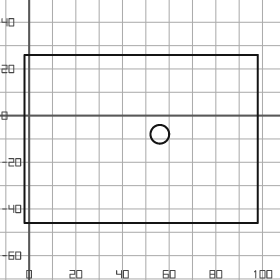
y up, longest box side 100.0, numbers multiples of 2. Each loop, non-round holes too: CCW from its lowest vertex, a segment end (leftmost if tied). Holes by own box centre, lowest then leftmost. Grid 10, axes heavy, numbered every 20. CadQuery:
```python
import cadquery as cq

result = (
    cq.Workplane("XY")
    .moveTo(-2.0, -46.0)
    .lineTo(98.0, -46.0)
    .lineTo(98.0, 26.0)
    .lineTo(-2.0, 26.0)
    .close()
    .moveTo(56.0, -8.0)
    .circle(4.0)
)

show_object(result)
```